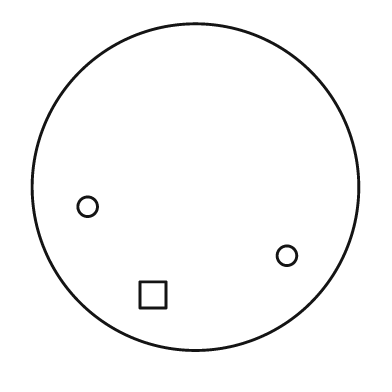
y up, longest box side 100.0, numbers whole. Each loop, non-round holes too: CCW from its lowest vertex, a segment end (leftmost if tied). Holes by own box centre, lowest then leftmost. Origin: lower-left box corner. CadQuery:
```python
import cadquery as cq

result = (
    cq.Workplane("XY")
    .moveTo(50.0, 50.0)
    .circle(50.0)
    .moveTo(33.0, 13.0)
    .lineTo(41.0, 13.0)
    .lineTo(41.0, 21.0)
    .lineTo(33.0, 21.0)
    .close()
    .moveTo(78.0, 29.0)
    .circle(3.0)
    .moveTo(17.0, 44.0)
    .circle(3.0)
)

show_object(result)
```